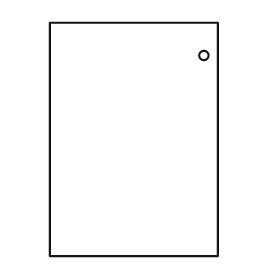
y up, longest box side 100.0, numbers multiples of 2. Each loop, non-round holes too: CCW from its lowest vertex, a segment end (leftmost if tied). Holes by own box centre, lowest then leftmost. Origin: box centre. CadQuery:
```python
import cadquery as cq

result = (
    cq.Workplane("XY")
    .moveTo(-36.0, -50.0)
    .lineTo(36.0, -50.0)
    .lineTo(36.0, 50.0)
    .lineTo(-36.0, 50.0)
    .close()
    .moveTo(30.0, 36.0)
    .circle(2.0)
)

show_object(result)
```